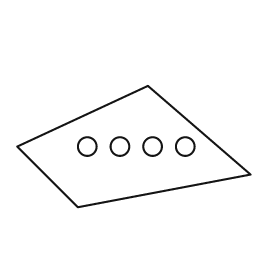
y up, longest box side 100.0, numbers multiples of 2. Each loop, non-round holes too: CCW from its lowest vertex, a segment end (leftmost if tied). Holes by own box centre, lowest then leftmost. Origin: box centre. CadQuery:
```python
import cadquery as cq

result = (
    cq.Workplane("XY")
    .moveTo(-24.0, -26.0)
    .lineTo(50.0, -12.0)
    .lineTo(6.0, 26.0)
    .lineTo(-50.0, 0.0)
    .close()
    .moveTo(-20.0, 0.0)
    .circle(4.0)
    .moveTo(-6.0, 0.0)
    .circle(4.0)
    .moveTo(8.0, 0.0)
    .circle(4.0)
    .moveTo(22.0, 0.0)
    .circle(4.0)
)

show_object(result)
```